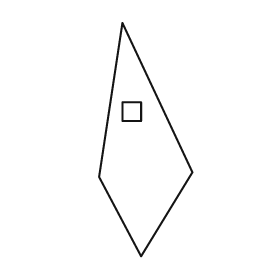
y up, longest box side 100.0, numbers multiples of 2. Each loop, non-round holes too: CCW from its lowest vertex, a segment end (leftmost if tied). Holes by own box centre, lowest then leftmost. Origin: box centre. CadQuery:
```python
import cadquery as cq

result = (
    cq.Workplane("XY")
    .moveTo(-2.0, -50.0)
    .lineTo(20.0, -14.0)
    .lineTo(-10.0, 50.0)
    .lineTo(-20.0, -16.0)
    .close()
    .moveTo(-10.0, 8.0)
    .lineTo(-2.0, 8.0)
    .lineTo(-2.0, 16.0)
    .lineTo(-10.0, 16.0)
    .close()
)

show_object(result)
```